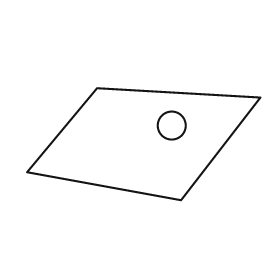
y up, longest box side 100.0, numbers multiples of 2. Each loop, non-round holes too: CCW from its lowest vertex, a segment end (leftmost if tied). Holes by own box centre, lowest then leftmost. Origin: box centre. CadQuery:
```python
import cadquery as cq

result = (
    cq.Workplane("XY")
    .moveTo(16.0, -24.0)
    .lineTo(50.0, 20.0)
    .lineTo(-20.0, 24.0)
    .lineTo(-50.0, -12.0)
    .close()
    .moveTo(12.0, 8.0)
    .circle(6.0)
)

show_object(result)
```